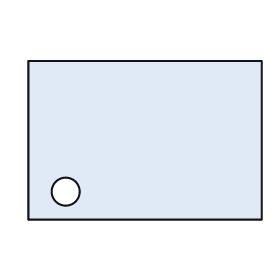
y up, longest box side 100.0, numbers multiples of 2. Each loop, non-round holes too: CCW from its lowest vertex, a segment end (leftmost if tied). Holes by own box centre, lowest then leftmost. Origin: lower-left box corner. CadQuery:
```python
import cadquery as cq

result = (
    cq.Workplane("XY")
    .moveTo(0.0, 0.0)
    .lineTo(100.0, 0.0)
    .lineTo(100.0, 68.0)
    .lineTo(0.0, 68.0)
    .close()
    .moveTo(16.0, 12.0)
    .circle(6.0)
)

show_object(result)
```